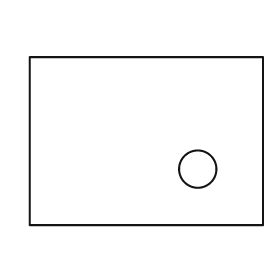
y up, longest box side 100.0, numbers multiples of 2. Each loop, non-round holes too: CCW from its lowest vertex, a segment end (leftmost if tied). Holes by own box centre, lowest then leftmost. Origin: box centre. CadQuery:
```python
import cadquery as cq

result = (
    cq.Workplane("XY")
    .moveTo(-50.0, -36.0)
    .lineTo(50.0, -36.0)
    .lineTo(50.0, 36.0)
    .lineTo(-50.0, 36.0)
    .close()
    .moveTo(22.0, -12.0)
    .circle(8.0)
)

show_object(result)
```